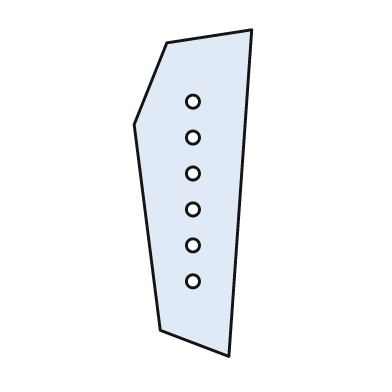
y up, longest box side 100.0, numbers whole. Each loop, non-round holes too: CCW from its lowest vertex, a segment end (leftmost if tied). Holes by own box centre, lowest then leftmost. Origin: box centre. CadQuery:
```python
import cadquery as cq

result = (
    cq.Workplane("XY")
    .moveTo(11.0, -50.0)
    .lineTo(18.0, 50.0)
    .lineTo(-8.0, 46.0)
    .lineTo(-18.0, 21.0)
    .lineTo(-10.0, -42.0)
    .close()
    .moveTo(0.0, -27.0)
    .circle(2.0)
    .moveTo(0.0, -16.0)
    .circle(2.0)
    .moveTo(0.0, -5.0)
    .circle(2.0)
    .moveTo(0.0, 6.0)
    .circle(2.0)
    .moveTo(0.0, 17.0)
    .circle(2.0)
    .moveTo(0.0, 28.0)
    .circle(2.0)
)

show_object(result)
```